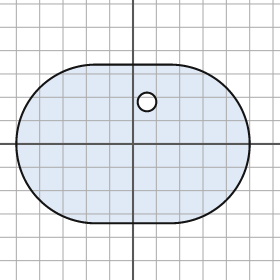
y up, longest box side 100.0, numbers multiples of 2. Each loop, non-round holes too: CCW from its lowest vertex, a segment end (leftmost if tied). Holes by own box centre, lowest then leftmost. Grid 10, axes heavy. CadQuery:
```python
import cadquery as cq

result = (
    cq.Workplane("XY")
    .moveTo(-16.0, -34.0)
    .lineTo(16.0, -34.0)
    .threePointArc((50.0, 0.0), (16.0, 34.0))
    .lineTo(-16.0, 34.0)
    .threePointArc((-50.0, 0.0), (-16.0, -34.0))
    .close()
    .moveTo(6.0, 18.0)
    .circle(4.0)
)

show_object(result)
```